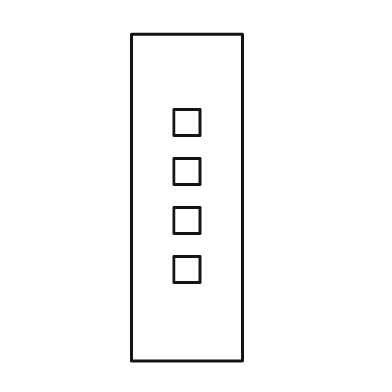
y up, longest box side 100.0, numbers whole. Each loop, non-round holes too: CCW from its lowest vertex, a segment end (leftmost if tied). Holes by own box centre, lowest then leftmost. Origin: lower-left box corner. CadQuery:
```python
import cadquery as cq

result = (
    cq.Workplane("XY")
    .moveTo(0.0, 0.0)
    .lineTo(34.0, 0.0)
    .lineTo(34.0, 100.0)
    .lineTo(0.0, 100.0)
    .close()
    .moveTo(13.0, 24.0)
    .lineTo(21.0, 24.0)
    .lineTo(21.0, 32.0)
    .lineTo(13.0, 32.0)
    .close()
    .moveTo(13.0, 39.0)
    .lineTo(21.0, 39.0)
    .lineTo(21.0, 47.0)
    .lineTo(13.0, 47.0)
    .close()
    .moveTo(13.0, 54.0)
    .lineTo(21.0, 54.0)
    .lineTo(21.0, 62.0)
    .lineTo(13.0, 62.0)
    .close()
    .moveTo(13.0, 69.0)
    .lineTo(21.0, 69.0)
    .lineTo(21.0, 77.0)
    .lineTo(13.0, 77.0)
    .close()
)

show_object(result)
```